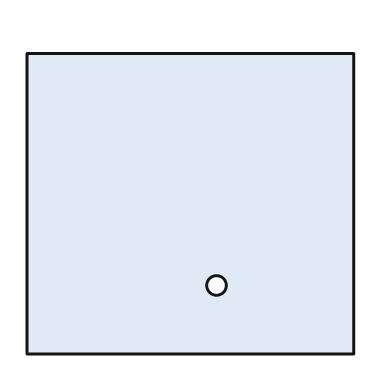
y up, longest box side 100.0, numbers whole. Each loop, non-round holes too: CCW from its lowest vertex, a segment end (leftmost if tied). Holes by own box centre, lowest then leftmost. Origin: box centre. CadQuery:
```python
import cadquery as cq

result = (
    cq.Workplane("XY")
    .moveTo(-50.0, -46.0)
    .lineTo(50.0, -46.0)
    .lineTo(50.0, 46.0)
    .lineTo(-50.0, 46.0)
    .close()
    .moveTo(8.0, -25.0)
    .circle(3.0)
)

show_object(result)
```